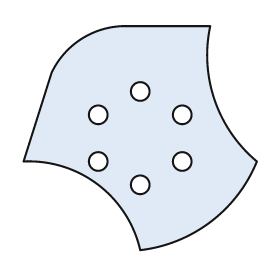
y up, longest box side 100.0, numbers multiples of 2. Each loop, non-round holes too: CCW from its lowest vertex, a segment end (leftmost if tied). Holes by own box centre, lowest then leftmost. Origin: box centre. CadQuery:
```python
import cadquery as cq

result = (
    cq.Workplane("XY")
    .moveTo(0.0, -48.0)
    .threePointArc((30.0, -36.0), (50.0, -10.0))
    .threePointArc((32.0, 16.0), (30.0, 48.0))
    .lineTo(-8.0, 48.0)
    .threePointArc((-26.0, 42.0), (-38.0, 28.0))
    .lineTo(-50.0, -10.0)
    .threePointArc((-18.0, -20.0), (0.0, -48.0))
    .close()
    .moveTo(0.0, -20.0)
    .circle(4.0)
    .moveTo(-18.0, -10.0)
    .circle(4.0)
    .moveTo(18.0, -10.0)
    .circle(4.0)
    .moveTo(-18.0, 10.0)
    .circle(4.0)
    .moveTo(18.0, 10.0)
    .circle(4.0)
    .moveTo(0.0, 20.0)
    .circle(4.0)
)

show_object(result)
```